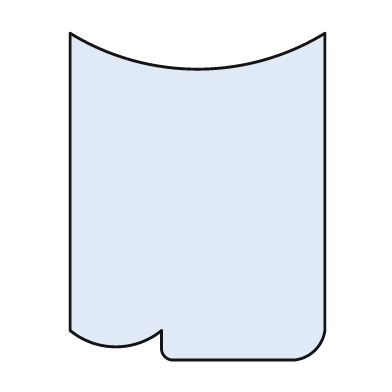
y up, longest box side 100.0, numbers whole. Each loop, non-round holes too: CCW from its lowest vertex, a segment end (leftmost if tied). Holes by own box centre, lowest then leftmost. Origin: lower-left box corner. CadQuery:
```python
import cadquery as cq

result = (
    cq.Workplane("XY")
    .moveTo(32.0, 0.0)
    .lineTo(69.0, 0.0)
    .threePointArc((75.0, 3.0), (78.0, 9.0))
    .lineTo(78.0, 100.0)
    .threePointArc((39.0, 89.0), (0.0, 100.0))
    .lineTo(0.0, 9.0)
    .threePointArc((14.0, 4.0), (28.0, 9.0))
    .lineTo(28.0, 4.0)
    .threePointArc((29.0, 1.0), (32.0, 0.0))
    .close()
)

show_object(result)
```